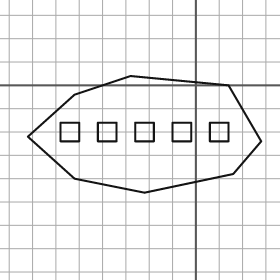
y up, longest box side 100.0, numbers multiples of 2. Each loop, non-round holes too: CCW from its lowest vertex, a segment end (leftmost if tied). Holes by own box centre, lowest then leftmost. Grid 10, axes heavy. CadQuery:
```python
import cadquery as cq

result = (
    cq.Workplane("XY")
    .moveTo(-22.0, -46.0)
    .lineTo(16.0, -38.0)
    .lineTo(28.0, -24.0)
    .lineTo(14.0, 0.0)
    .lineTo(-28.0, 4.0)
    .lineTo(-52.0, -4.0)
    .lineTo(-72.0, -22.0)
    .lineTo(-52.0, -40.0)
    .close()
    .moveTo(-58.0, -24.0)
    .lineTo(-50.0, -24.0)
    .lineTo(-50.0, -16.0)
    .lineTo(-58.0, -16.0)
    .close()
    .moveTo(-42.0, -24.0)
    .lineTo(-34.0, -24.0)
    .lineTo(-34.0, -16.0)
    .lineTo(-42.0, -16.0)
    .close()
    .moveTo(-26.0, -24.0)
    .lineTo(-18.0, -24.0)
    .lineTo(-18.0, -16.0)
    .lineTo(-26.0, -16.0)
    .close()
    .moveTo(-10.0, -24.0)
    .lineTo(-2.0, -24.0)
    .lineTo(-2.0, -16.0)
    .lineTo(-10.0, -16.0)
    .close()
    .moveTo(6.0, -24.0)
    .lineTo(14.0, -24.0)
    .lineTo(14.0, -16.0)
    .lineTo(6.0, -16.0)
    .close()
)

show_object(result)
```